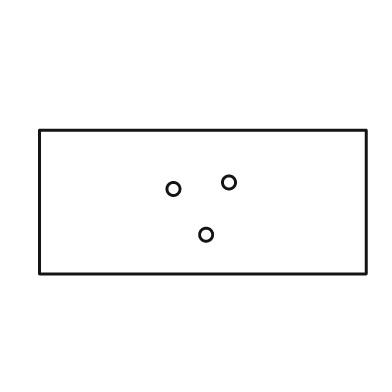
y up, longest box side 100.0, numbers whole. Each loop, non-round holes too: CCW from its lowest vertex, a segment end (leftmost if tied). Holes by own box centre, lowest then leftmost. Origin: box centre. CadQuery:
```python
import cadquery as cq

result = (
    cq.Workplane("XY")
    .moveTo(-50.0, -22.0)
    .lineTo(50.0, -22.0)
    .lineTo(50.0, 22.0)
    .lineTo(-50.0, 22.0)
    .close()
    .moveTo(1.0, -10.0)
    .circle(2.0)
    .moveTo(-9.0, 4.0)
    .circle(2.0)
    .moveTo(8.0, 6.0)
    .circle(2.0)
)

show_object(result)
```